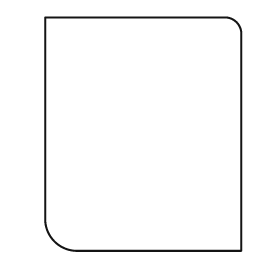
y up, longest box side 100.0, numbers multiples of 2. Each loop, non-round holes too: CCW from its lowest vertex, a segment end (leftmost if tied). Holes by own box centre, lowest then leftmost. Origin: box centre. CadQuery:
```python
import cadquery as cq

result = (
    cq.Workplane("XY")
    .moveTo(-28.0, -50.0)
    .lineTo(42.0, -50.0)
    .lineTo(42.0, 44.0)
    .threePointArc((40.0, 48.0), (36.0, 50.0))
    .lineTo(-42.0, 50.0)
    .lineTo(-42.0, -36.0)
    .threePointArc((-38.0, -46.0), (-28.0, -50.0))
    .close()
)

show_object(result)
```